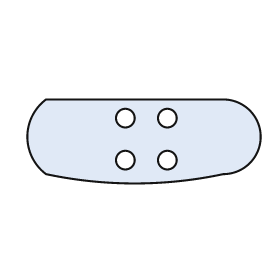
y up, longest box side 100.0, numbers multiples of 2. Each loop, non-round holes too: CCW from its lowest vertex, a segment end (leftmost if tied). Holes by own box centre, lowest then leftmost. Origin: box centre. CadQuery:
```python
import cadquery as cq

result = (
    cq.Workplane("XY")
    .moveTo(-42.0, -14.0)
    .threePointArc((-4.0, -18.0), (34.0, -14.0))
    .threePointArc((50.0, 2.0), (34.0, 18.0))
    .lineTo(-42.0, 18.0)
    .threePointArc((-50.0, 2.0), (-42.0, -14.0))
    .close()
    .moveTo(-8.0, -8.0)
    .circle(4.0)
    .moveTo(10.0, -8.0)
    .circle(4.0)
    .moveTo(-8.0, 10.0)
    .circle(4.0)
    .moveTo(10.0, 10.0)
    .circle(4.0)
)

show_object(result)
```